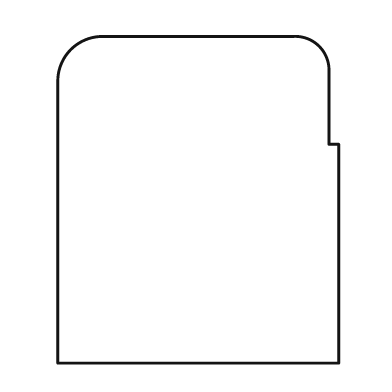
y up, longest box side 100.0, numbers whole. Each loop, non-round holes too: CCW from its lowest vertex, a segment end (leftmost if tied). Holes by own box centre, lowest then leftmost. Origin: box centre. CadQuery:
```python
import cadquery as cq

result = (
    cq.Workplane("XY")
    .moveTo(-43.0, -50.0)
    .lineTo(43.0, -50.0)
    .lineTo(43.0, 17.0)
    .lineTo(40.0, 17.0)
    .lineTo(40.0, 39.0)
    .threePointArc((37.0, 47.0), (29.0, 50.0))
    .lineTo(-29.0, 50.0)
    .threePointArc((-39.0, 46.0), (-43.0, 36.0))
    .close()
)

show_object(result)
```